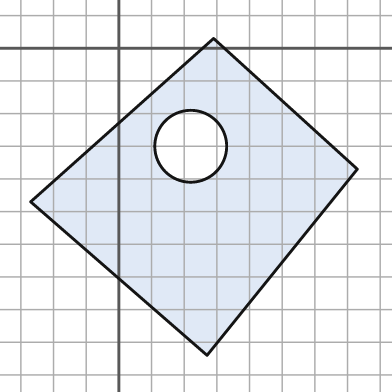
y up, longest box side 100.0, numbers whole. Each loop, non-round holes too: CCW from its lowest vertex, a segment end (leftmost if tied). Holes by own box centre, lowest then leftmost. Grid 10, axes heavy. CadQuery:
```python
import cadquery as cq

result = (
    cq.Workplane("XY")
    .moveTo(27.0, -94.0)
    .lineTo(73.0, -37.0)
    .lineTo(29.0, 3.0)
    .lineTo(-27.0, -47.0)
    .close()
    .moveTo(22.0, -30.0)
    .circle(11.0)
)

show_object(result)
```